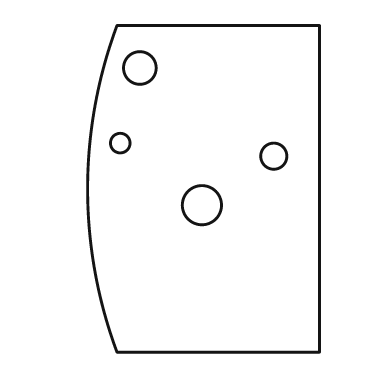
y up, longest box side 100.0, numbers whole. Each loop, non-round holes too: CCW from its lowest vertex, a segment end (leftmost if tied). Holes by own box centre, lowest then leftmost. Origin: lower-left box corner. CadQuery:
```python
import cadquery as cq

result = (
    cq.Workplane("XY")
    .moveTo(9.0, 0.0)
    .lineTo(71.0, 0.0)
    .lineTo(71.0, 100.0)
    .lineTo(9.0, 100.0)
    .threePointArc((0.0, 50.0), (9.0, 0.0))
    .close()
    .moveTo(35.0, 45.0)
    .circle(6.0)
    .moveTo(57.0, 60.0)
    .circle(4.0)
    .moveTo(10.0, 64.0)
    .circle(3.0)
    .moveTo(16.0, 87.0)
    .circle(5.0)
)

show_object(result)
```